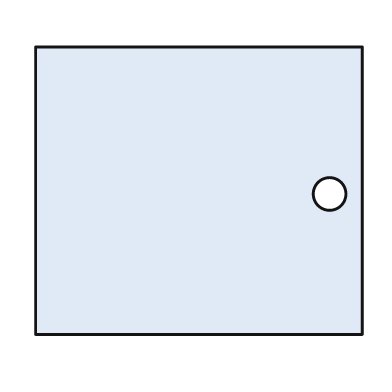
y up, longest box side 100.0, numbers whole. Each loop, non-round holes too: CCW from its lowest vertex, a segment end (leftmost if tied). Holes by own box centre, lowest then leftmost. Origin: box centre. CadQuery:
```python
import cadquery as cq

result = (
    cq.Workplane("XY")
    .moveTo(-50.0, -44.0)
    .lineTo(50.0, -44.0)
    .lineTo(50.0, 44.0)
    .lineTo(-50.0, 44.0)
    .close()
    .moveTo(40.0, -1.0)
    .circle(5.0)
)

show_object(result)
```